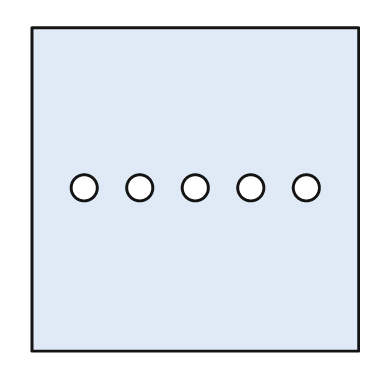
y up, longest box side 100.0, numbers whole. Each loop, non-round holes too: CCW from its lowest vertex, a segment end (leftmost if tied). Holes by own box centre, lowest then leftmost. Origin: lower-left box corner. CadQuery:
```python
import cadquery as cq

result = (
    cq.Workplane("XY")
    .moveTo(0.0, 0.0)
    .lineTo(100.0, 0.0)
    .lineTo(100.0, 99.0)
    .lineTo(0.0, 99.0)
    .close()
    .moveTo(16.0, 50.0)
    .circle(4.0)
    .moveTo(33.0, 50.0)
    .circle(4.0)
    .moveTo(50.0, 50.0)
    .circle(4.0)
    .moveTo(67.0, 50.0)
    .circle(4.0)
    .moveTo(84.0, 50.0)
    .circle(4.0)
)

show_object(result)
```